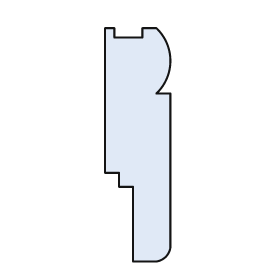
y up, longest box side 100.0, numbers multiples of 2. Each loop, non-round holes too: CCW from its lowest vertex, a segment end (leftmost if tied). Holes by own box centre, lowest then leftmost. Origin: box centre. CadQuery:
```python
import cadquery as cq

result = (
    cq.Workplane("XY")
    .moveTo(-2.0, -50.0)
    .lineTo(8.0, -50.0)
    .threePointArc((12.0, -48.0), (14.0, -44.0))
    .lineTo(14.0, 22.0)
    .lineTo(8.0, 22.0)
    .threePointArc((14.0, 36.0), (8.0, 50.0))
    .lineTo(2.0, 50.0)
    .lineTo(2.0, 46.0)
    .lineTo(-10.0, 46.0)
    .lineTo(-10.0, 50.0)
    .lineTo(-14.0, 50.0)
    .lineTo(-14.0, -12.0)
    .lineTo(-8.0, -12.0)
    .lineTo(-8.0, -18.0)
    .lineTo(-2.0, -18.0)
    .close()
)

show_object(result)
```